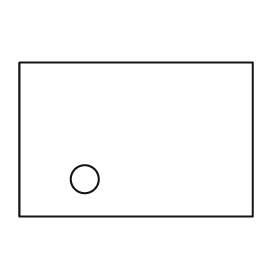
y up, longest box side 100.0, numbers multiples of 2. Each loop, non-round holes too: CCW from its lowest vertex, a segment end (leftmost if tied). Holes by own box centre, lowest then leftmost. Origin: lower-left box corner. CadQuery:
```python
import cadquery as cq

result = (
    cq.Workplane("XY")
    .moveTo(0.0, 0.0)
    .lineTo(100.0, 0.0)
    .lineTo(100.0, 66.0)
    .lineTo(0.0, 66.0)
    .close()
    .moveTo(28.0, 16.0)
    .circle(6.0)
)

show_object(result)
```